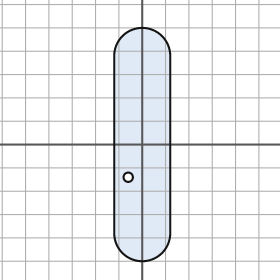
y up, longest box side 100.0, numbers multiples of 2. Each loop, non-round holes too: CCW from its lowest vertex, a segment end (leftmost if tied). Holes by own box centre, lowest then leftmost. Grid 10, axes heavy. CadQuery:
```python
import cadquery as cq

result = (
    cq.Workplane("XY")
    .moveTo(-12.0, -38.0)
    .threePointArc((0.0, -50.0), (12.0, -38.0))
    .lineTo(12.0, 38.0)
    .threePointArc((0.0, 50.0), (-12.0, 38.0))
    .close()
    .moveTo(-6.0, -14.0)
    .circle(2.0)
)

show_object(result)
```